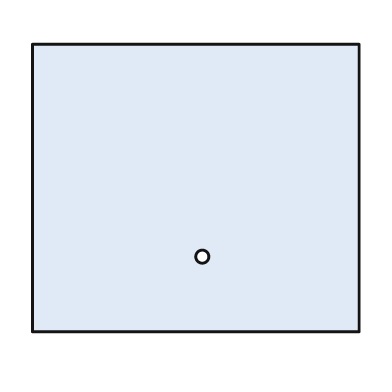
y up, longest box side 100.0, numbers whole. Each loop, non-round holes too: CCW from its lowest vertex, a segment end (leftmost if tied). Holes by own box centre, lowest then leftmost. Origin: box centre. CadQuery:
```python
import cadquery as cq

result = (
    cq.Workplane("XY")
    .moveTo(-50.0, -44.0)
    .lineTo(50.0, -44.0)
    .lineTo(50.0, 44.0)
    .lineTo(-50.0, 44.0)
    .close()
    .moveTo(2.0, -21.0)
    .circle(2.0)
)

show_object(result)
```